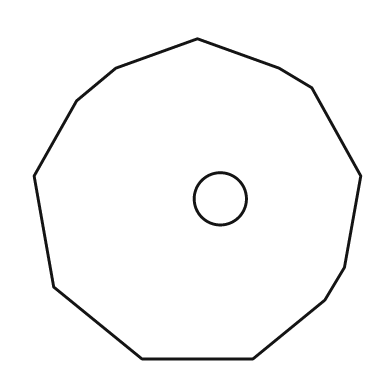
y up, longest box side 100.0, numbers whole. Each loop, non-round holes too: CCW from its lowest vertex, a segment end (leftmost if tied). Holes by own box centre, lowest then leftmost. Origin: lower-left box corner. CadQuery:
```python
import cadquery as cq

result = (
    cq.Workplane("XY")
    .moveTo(33.0, 0.0)
    .lineTo(67.0, 0.0)
    .lineTo(89.0, 18.0)
    .lineTo(95.0, 28.0)
    .lineTo(100.0, 56.0)
    .lineTo(85.0, 83.0)
    .lineTo(75.0, 89.0)
    .lineTo(50.0, 98.0)
    .lineTo(25.0, 89.0)
    .lineTo(13.0, 79.0)
    .lineTo(0.0, 56.0)
    .lineTo(6.0, 22.0)
    .close()
    .moveTo(57.0, 49.0)
    .circle(8.0)
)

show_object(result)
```